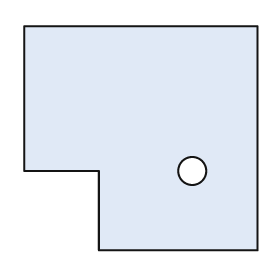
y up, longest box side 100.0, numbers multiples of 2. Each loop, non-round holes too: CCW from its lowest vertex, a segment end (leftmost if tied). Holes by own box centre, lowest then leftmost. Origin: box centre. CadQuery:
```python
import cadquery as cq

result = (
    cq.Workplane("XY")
    .moveTo(-18.0, -48.0)
    .lineTo(50.0, -48.0)
    .lineTo(50.0, 48.0)
    .lineTo(-50.0, 48.0)
    .lineTo(-50.0, -14.0)
    .lineTo(-18.0, -14.0)
    .close()
    .moveTo(22.0, -14.0)
    .circle(6.0)
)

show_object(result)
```